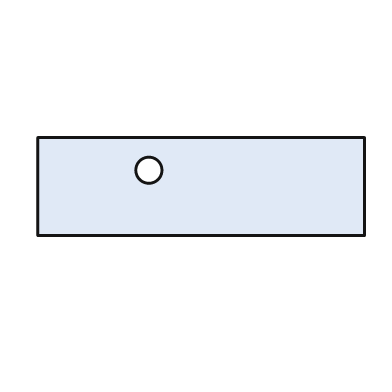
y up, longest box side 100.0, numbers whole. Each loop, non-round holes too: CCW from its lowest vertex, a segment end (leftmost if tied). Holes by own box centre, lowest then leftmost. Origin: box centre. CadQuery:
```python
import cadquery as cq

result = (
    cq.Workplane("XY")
    .moveTo(-50.0, -15.0)
    .lineTo(50.0, -15.0)
    .lineTo(50.0, 15.0)
    .lineTo(-50.0, 15.0)
    .close()
    .moveTo(-16.0, 5.0)
    .circle(4.0)
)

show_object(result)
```